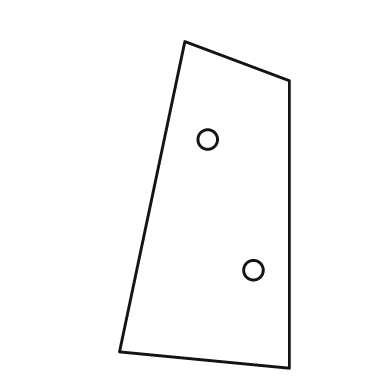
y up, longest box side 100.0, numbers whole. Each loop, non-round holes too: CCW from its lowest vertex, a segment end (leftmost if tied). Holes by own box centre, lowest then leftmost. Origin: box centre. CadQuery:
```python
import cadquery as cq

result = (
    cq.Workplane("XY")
    .moveTo(26.0, -50.0)
    .lineTo(26.0, 38.0)
    .lineTo(-6.0, 50.0)
    .lineTo(-26.0, -45.0)
    .close()
    .moveTo(15.0, -20.0)
    .circle(3.0)
    .moveTo(1.0, 20.0)
    .circle(3.0)
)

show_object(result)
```